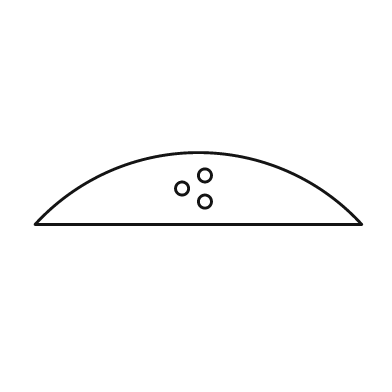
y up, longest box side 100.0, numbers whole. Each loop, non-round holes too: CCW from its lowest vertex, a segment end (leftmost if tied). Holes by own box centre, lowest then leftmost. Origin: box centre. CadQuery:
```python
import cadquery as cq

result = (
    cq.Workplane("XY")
    .moveTo(-50.0, -11.0)
    .lineTo(50.0, -11.0)
    .threePointArc((0.0, 11.0), (-50.0, -11.0))
    .close()
    .moveTo(2.0, -4.0)
    .circle(2.0)
    .moveTo(-5.0, 0.0)
    .circle(2.0)
    .moveTo(2.0, 4.0)
    .circle(2.0)
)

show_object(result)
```